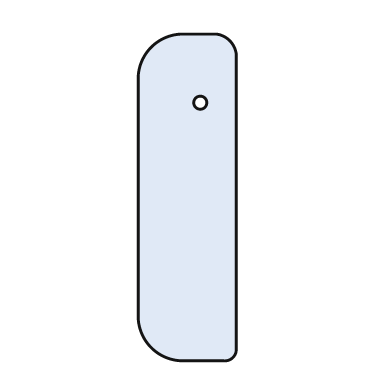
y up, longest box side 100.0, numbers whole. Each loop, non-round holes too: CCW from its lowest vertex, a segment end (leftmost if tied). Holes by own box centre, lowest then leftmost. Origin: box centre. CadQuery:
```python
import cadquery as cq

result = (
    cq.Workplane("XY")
    .moveTo(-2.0, -50.0)
    .lineTo(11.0, -50.0)
    .threePointArc((14.0, -49.0), (15.0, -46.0))
    .lineTo(15.0, 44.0)
    .threePointArc((13.0, 48.0), (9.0, 50.0))
    .lineTo(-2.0, 50.0)
    .threePointArc((-11.0, 46.0), (-15.0, 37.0))
    .lineTo(-15.0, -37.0)
    .threePointArc((-11.0, -46.0), (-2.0, -50.0))
    .close()
    .moveTo(4.0, 29.0)
    .circle(2.0)
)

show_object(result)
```